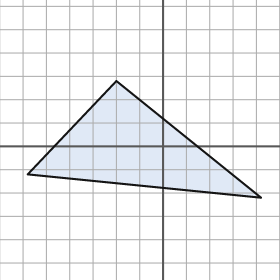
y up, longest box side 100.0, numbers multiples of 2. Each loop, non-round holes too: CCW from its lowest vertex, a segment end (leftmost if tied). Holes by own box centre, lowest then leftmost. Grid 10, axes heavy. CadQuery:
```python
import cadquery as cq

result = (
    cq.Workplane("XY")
    .moveTo(42.0, -22.0)
    .lineTo(-20.0, 28.0)
    .lineTo(-58.0, -12.0)
    .close()
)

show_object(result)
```